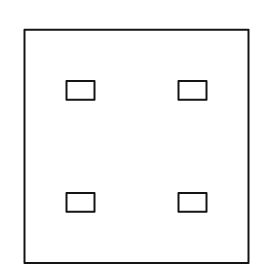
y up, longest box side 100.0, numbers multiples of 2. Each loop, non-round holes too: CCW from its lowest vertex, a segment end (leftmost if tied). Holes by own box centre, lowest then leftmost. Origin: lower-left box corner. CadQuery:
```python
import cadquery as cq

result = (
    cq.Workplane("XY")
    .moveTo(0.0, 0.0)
    .lineTo(96.0, 0.0)
    .lineTo(96.0, 100.0)
    .lineTo(0.0, 100.0)
    .close()
    .moveTo(18.0, 22.0)
    .lineTo(30.0, 22.0)
    .lineTo(30.0, 30.0)
    .lineTo(18.0, 30.0)
    .close()
    .moveTo(66.0, 22.0)
    .lineTo(78.0, 22.0)
    .lineTo(78.0, 30.0)
    .lineTo(66.0, 30.0)
    .close()
    .moveTo(18.0, 70.0)
    .lineTo(30.0, 70.0)
    .lineTo(30.0, 78.0)
    .lineTo(18.0, 78.0)
    .close()
    .moveTo(66.0, 70.0)
    .lineTo(78.0, 70.0)
    .lineTo(78.0, 78.0)
    .lineTo(66.0, 78.0)
    .close()
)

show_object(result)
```